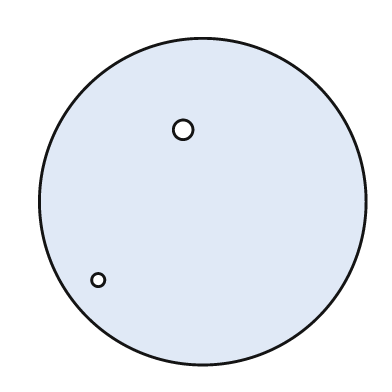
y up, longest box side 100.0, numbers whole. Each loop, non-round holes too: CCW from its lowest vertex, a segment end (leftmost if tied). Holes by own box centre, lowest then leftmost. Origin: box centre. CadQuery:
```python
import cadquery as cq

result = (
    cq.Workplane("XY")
    .moveTo(0.0, 0.0)
    .circle(50.0)
    .moveTo(-32.0, -24.0)
    .circle(2.0)
    .moveTo(-6.0, 22.0)
    .circle(3.0)
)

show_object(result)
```